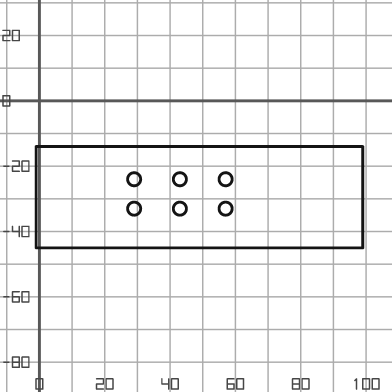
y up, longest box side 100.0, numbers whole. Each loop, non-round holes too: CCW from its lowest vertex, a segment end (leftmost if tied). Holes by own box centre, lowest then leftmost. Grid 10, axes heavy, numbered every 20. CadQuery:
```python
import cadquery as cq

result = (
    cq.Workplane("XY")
    .moveTo(-1.0, -45.0)
    .lineTo(99.0, -45.0)
    .lineTo(99.0, -14.0)
    .lineTo(-1.0, -14.0)
    .close()
    .moveTo(29.0, -33.0)
    .circle(2.0)
    .moveTo(43.0, -33.0)
    .circle(2.0)
    .moveTo(57.0, -33.0)
    .circle(2.0)
    .moveTo(29.0, -24.0)
    .circle(2.0)
    .moveTo(43.0, -24.0)
    .circle(2.0)
    .moveTo(57.0, -24.0)
    .circle(2.0)
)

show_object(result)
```